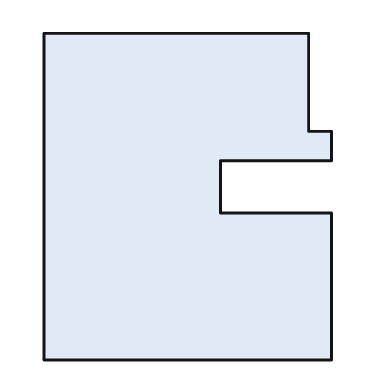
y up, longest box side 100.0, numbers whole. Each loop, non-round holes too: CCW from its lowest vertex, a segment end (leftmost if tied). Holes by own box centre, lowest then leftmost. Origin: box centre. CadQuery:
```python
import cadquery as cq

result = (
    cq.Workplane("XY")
    .moveTo(-44.0, -50.0)
    .lineTo(44.0, -50.0)
    .lineTo(44.0, -5.0)
    .lineTo(10.0, -5.0)
    .lineTo(10.0, 11.0)
    .lineTo(44.0, 11.0)
    .lineTo(44.0, 20.0)
    .lineTo(37.0, 20.0)
    .lineTo(37.0, 50.0)
    .lineTo(-44.0, 50.0)
    .close()
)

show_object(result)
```